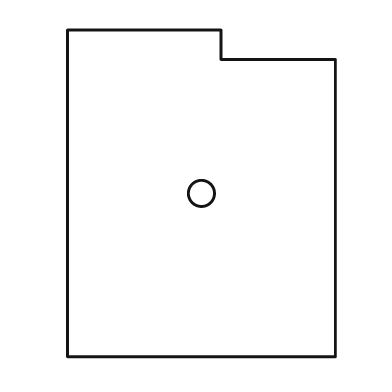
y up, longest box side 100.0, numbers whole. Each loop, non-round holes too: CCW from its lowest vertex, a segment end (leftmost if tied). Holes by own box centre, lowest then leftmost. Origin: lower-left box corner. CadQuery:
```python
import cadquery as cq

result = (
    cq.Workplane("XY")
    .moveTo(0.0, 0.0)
    .lineTo(82.0, 0.0)
    .lineTo(82.0, 91.0)
    .lineTo(47.0, 91.0)
    .lineTo(47.0, 100.0)
    .lineTo(0.0, 100.0)
    .close()
    .moveTo(41.0, 50.0)
    .circle(4.0)
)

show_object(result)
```